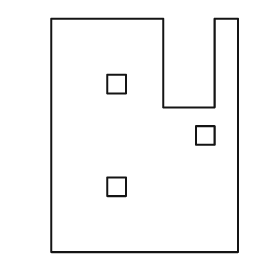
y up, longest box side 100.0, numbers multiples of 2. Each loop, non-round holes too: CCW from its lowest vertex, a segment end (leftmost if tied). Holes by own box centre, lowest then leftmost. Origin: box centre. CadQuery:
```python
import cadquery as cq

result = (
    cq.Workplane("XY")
    .moveTo(-40.0, -50.0)
    .lineTo(40.0, -50.0)
    .lineTo(40.0, 50.0)
    .lineTo(30.0, 50.0)
    .lineTo(30.0, 12.0)
    .lineTo(8.0, 12.0)
    .lineTo(8.0, 50.0)
    .lineTo(-40.0, 50.0)
    .close()
    .moveTo(-16.0, -26.0)
    .lineTo(-8.0, -26.0)
    .lineTo(-8.0, -18.0)
    .lineTo(-16.0, -18.0)
    .close()
    .moveTo(22.0, -4.0)
    .lineTo(30.0, -4.0)
    .lineTo(30.0, 4.0)
    .lineTo(22.0, 4.0)
    .close()
    .moveTo(-16.0, 18.0)
    .lineTo(-8.0, 18.0)
    .lineTo(-8.0, 26.0)
    .lineTo(-16.0, 26.0)
    .close()
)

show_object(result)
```